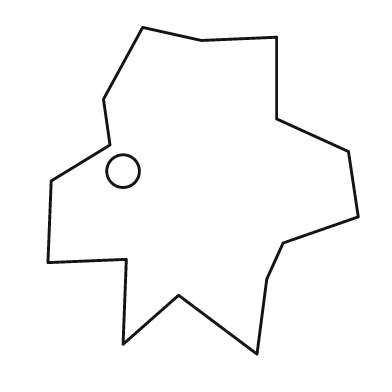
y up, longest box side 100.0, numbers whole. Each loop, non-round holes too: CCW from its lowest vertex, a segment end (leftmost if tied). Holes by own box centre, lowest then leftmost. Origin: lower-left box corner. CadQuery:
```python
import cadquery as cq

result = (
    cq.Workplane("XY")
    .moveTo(64.0, 0.0)
    .lineTo(67.0, 23.0)
    .lineTo(72.0, 34.0)
    .lineTo(95.0, 42.0)
    .lineTo(92.0, 62.0)
    .lineTo(70.0, 72.0)
    .lineTo(70.0, 97.0)
    .lineTo(47.0, 96.0)
    .lineTo(29.0, 100.0)
    .lineTo(17.0, 78.0)
    .lineTo(19.0, 64.0)
    .lineTo(1.0, 53.0)
    .lineTo(0.0, 28.0)
    .lineTo(24.0, 29.0)
    .lineTo(23.0, 3.0)
    .lineTo(40.0, 18.0)
    .close()
    .moveTo(23.0, 56.0)
    .circle(5.0)
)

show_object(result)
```